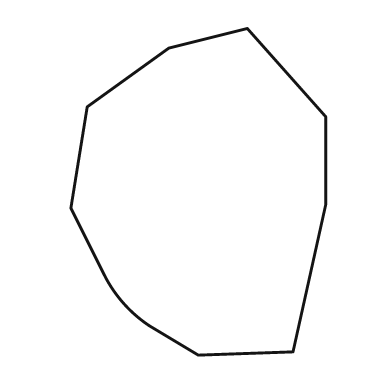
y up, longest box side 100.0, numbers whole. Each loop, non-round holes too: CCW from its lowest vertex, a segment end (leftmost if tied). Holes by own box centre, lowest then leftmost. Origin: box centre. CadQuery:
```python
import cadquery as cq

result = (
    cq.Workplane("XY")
    .moveTo(0.0, -50.0)
    .lineTo(29.0, -49.0)
    .lineTo(39.0, -4.0)
    .lineTo(39.0, 23.0)
    .lineTo(15.0, 50.0)
    .lineTo(-9.0, 44.0)
    .lineTo(-34.0, 26.0)
    .lineTo(-39.0, -5.0)
    .lineTo(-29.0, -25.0)
    .threePointArc((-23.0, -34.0), (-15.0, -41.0))
    .close()
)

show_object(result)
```